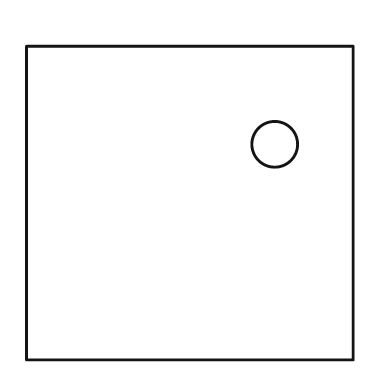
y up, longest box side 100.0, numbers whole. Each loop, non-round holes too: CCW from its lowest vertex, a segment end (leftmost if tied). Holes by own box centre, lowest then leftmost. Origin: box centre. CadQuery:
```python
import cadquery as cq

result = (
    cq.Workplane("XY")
    .moveTo(-50.0, -48.0)
    .lineTo(50.0, -48.0)
    .lineTo(50.0, 48.0)
    .lineTo(-50.0, 48.0)
    .close()
    .moveTo(26.0, 18.0)
    .circle(7.0)
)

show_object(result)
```